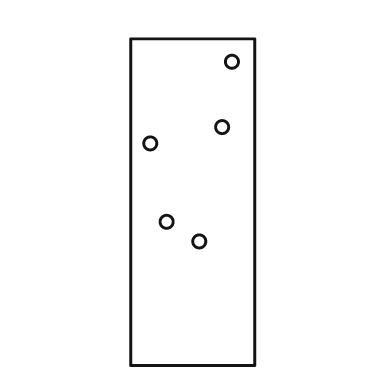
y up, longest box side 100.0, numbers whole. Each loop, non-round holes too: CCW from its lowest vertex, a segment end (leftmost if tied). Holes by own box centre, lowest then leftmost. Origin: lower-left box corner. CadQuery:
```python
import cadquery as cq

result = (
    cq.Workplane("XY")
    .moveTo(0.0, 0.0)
    .lineTo(38.0, 0.0)
    .lineTo(38.0, 100.0)
    .lineTo(0.0, 100.0)
    .close()
    .moveTo(21.0, 38.0)
    .circle(2.0)
    .moveTo(11.0, 44.0)
    .circle(2.0)
    .moveTo(6.0, 68.0)
    .circle(2.0)
    .moveTo(28.0, 73.0)
    .circle(2.0)
    .moveTo(31.0, 93.0)
    .circle(2.0)
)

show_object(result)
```